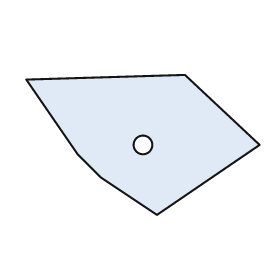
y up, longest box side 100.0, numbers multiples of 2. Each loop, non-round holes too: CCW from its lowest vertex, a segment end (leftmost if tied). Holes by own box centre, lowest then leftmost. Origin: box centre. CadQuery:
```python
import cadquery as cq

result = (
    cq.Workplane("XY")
    .moveTo(6.0, -30.0)
    .lineTo(50.0, 0.0)
    .lineTo(18.0, 30.0)
    .lineTo(-50.0, 28.0)
    .lineTo(-28.0, -4.0)
    .lineTo(-18.0, -14.0)
    .close()
    .moveTo(0.0, 0.0)
    .circle(4.0)
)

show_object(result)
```